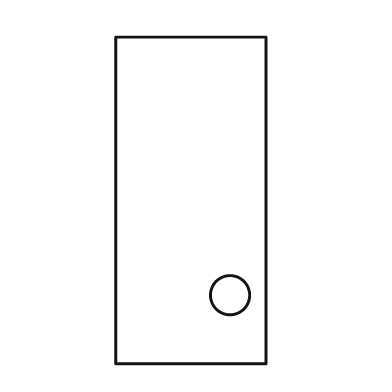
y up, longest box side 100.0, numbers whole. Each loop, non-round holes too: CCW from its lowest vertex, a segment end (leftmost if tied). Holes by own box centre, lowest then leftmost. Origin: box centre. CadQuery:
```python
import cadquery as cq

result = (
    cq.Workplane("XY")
    .moveTo(-23.0, -50.0)
    .lineTo(23.0, -50.0)
    .lineTo(23.0, 50.0)
    .lineTo(-23.0, 50.0)
    .close()
    .moveTo(12.0, -29.0)
    .circle(6.0)
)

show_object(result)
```